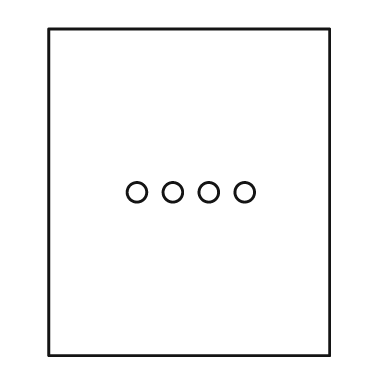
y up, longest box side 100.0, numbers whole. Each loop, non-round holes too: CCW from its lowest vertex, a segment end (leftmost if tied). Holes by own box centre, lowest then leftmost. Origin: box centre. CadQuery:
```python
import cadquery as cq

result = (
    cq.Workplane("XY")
    .moveTo(-43.0, -50.0)
    .lineTo(43.0, -50.0)
    .lineTo(43.0, 50.0)
    .lineTo(-43.0, 50.0)
    .close()
    .moveTo(-16.0, 0.0)
    .circle(3.0)
    .moveTo(-5.0, 0.0)
    .circle(3.0)
    .moveTo(6.0, 0.0)
    .circle(3.0)
    .moveTo(17.0, 0.0)
    .circle(3.0)
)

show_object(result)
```